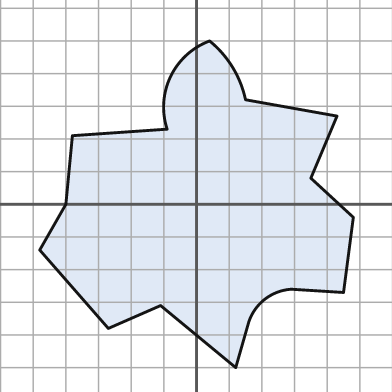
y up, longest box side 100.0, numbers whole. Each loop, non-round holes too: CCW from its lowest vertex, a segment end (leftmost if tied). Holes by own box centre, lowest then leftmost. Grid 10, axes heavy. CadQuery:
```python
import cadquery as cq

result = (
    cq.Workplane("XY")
    .moveTo(12.0, -50.0)
    .lineTo(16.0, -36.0)
    .threePointArc((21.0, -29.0), (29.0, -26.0))
    .lineTo(45.0, -27.0)
    .lineTo(48.0, -4.0)
    .lineTo(35.0, 8.0)
    .lineTo(43.0, 27.0)
    .lineTo(15.0, 32.0)
    .threePointArc((11.0, 42.0), (4.0, 50.0))
    .threePointArc((-8.0, 39.0), (-9.0, 23.0))
    .lineTo(-38.0, 21.0)
    .lineTo(-40.0, 0.0)
    .lineTo(-48.0, -14.0)
    .lineTo(-27.0, -38.0)
    .lineTo(-11.0, -31.0)
    .close()
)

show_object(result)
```